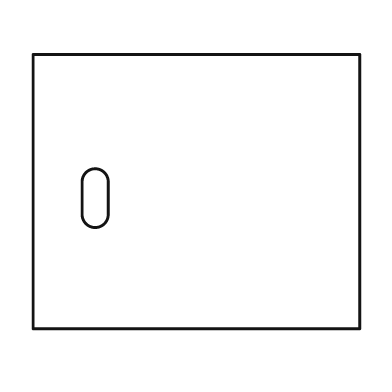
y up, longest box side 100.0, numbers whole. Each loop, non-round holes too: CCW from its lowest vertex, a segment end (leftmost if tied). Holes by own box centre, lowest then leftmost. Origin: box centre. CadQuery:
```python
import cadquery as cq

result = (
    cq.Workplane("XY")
    .moveTo(-50.0, -42.0)
    .lineTo(50.0, -42.0)
    .lineTo(50.0, 42.0)
    .lineTo(-50.0, 42.0)
    .close()
    .moveTo(-35.0, -7.0)
    .threePointArc((-31.0, -11.0), (-27.0, -7.0))
    .lineTo(-27.0, 3.0)
    .threePointArc((-31.0, 7.0), (-35.0, 3.0))
    .close()
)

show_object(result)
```